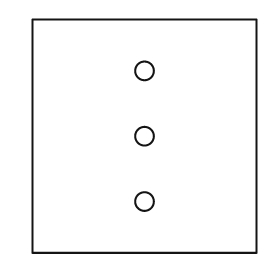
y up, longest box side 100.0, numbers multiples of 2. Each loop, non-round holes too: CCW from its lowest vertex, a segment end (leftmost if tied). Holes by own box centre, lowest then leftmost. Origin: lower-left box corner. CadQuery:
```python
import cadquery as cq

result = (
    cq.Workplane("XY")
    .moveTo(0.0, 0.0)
    .lineTo(96.0, 0.0)
    .lineTo(96.0, 100.0)
    .lineTo(0.0, 100.0)
    .close()
    .moveTo(48.0, 22.0)
    .circle(4.0)
    .moveTo(48.0, 50.0)
    .circle(4.0)
    .moveTo(48.0, 78.0)
    .circle(4.0)
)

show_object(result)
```